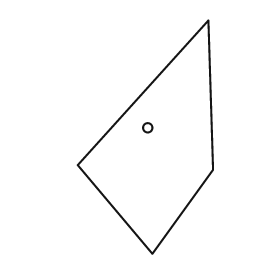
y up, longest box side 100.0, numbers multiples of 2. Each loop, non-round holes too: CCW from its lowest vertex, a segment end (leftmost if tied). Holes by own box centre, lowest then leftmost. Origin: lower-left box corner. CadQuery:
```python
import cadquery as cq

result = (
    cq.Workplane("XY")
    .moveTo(32.0, 0.0)
    .lineTo(58.0, 36.0)
    .lineTo(56.0, 100.0)
    .lineTo(0.0, 38.0)
    .close()
    .moveTo(30.0, 54.0)
    .circle(2.0)
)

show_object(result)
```